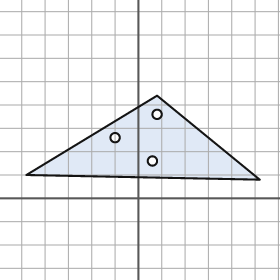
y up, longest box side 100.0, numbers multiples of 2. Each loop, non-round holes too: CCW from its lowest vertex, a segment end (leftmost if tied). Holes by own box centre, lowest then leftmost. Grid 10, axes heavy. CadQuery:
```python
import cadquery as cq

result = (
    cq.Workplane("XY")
    .moveTo(52.0, 8.0)
    .lineTo(8.0, 44.0)
    .lineTo(-48.0, 10.0)
    .close()
    .moveTo(6.0, 16.0)
    .circle(2.0)
    .moveTo(-10.0, 26.0)
    .circle(2.0)
    .moveTo(8.0, 36.0)
    .circle(2.0)
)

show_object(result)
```